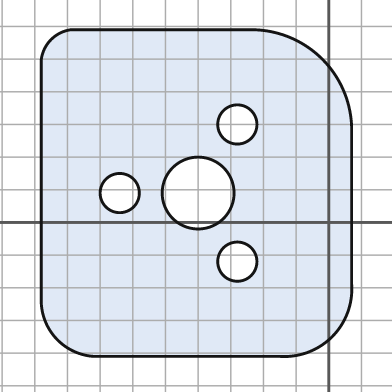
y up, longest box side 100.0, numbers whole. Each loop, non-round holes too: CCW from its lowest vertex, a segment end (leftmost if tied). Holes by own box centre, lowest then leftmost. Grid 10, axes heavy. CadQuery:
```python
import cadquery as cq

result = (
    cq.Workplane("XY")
    .moveTo(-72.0, -41.0)
    .lineTo(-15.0, -41.0)
    .threePointArc((1.0, -35.0), (7.0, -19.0))
    .lineTo(7.0, 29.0)
    .threePointArc((-2.0, 50.0), (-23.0, 59.0))
    .lineTo(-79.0, 59.0)
    .threePointArc((-85.0, 56.0), (-88.0, 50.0))
    .lineTo(-88.0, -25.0)
    .threePointArc((-83.0, -36.0), (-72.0, -41.0))
    .close()
    .moveTo(-28.0, -12.0)
    .circle(6.0)
    .moveTo(-64.0, 9.0)
    .circle(6.0)
    .moveTo(-40.0, 9.0)
    .circle(11.0)
    .moveTo(-28.0, 30.0)
    .circle(6.0)
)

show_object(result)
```